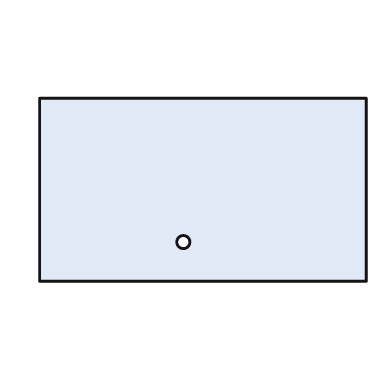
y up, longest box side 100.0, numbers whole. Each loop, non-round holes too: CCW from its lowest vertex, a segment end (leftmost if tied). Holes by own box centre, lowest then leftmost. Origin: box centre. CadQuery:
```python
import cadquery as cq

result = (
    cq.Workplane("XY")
    .moveTo(-50.0, -28.0)
    .lineTo(50.0, -28.0)
    .lineTo(50.0, 28.0)
    .lineTo(-50.0, 28.0)
    .close()
    .moveTo(-6.0, -16.0)
    .circle(2.0)
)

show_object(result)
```